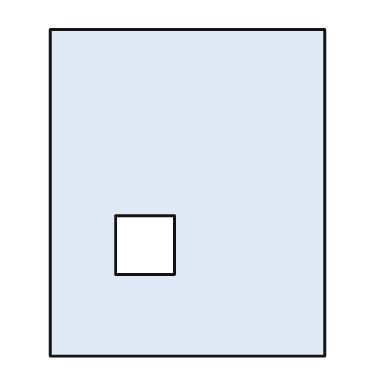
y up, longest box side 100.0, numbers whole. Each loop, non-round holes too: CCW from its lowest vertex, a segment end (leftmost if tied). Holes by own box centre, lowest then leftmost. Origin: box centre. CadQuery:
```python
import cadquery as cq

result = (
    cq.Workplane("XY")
    .moveTo(-42.0, -50.0)
    .lineTo(42.0, -50.0)
    .lineTo(42.0, 50.0)
    .lineTo(-42.0, 50.0)
    .close()
    .moveTo(-22.0, -25.0)
    .lineTo(-4.0, -25.0)
    .lineTo(-4.0, -7.0)
    .lineTo(-22.0, -7.0)
    .close()
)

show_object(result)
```